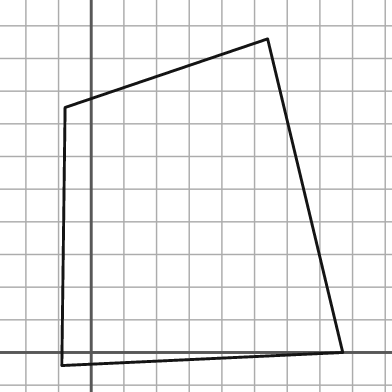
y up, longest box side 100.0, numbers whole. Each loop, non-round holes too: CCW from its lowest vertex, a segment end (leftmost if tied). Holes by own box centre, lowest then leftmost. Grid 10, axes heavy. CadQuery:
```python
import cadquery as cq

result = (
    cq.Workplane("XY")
    .moveTo(-9.0, -4.0)
    .lineTo(77.0, 0.0)
    .lineTo(54.0, 96.0)
    .lineTo(-8.0, 75.0)
    .close()
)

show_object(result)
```